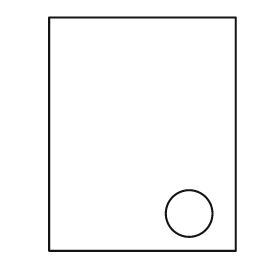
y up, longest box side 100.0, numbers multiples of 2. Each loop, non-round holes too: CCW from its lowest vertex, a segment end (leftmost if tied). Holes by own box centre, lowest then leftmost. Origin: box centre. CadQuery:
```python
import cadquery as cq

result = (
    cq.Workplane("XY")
    .moveTo(-40.0, -50.0)
    .lineTo(40.0, -50.0)
    .lineTo(40.0, 50.0)
    .lineTo(-40.0, 50.0)
    .close()
    .moveTo(20.0, -34.0)
    .circle(10.0)
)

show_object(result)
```